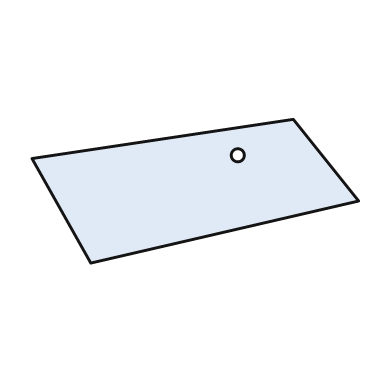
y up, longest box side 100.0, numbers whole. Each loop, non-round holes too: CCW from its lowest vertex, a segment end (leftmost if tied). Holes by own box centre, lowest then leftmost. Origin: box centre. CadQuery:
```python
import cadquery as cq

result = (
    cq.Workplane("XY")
    .moveTo(-32.0, -22.0)
    .lineTo(50.0, -3.0)
    .lineTo(30.0, 22.0)
    .lineTo(-50.0, 10.0)
    .close()
    .moveTo(13.0, 11.0)
    .circle(2.0)
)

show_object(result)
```